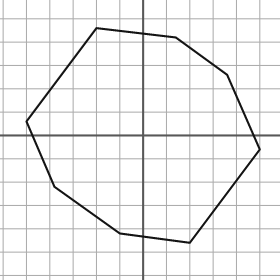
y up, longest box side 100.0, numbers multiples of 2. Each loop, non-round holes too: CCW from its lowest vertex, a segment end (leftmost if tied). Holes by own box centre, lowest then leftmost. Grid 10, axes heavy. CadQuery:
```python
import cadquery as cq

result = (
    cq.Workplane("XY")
    .moveTo(20.0, -46.0)
    .lineTo(50.0, -6.0)
    .lineTo(36.0, 26.0)
    .lineTo(14.0, 42.0)
    .lineTo(-20.0, 46.0)
    .lineTo(-50.0, 6.0)
    .lineTo(-38.0, -22.0)
    .lineTo(-10.0, -42.0)
    .close()
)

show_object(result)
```